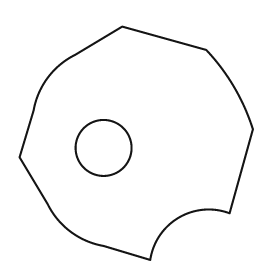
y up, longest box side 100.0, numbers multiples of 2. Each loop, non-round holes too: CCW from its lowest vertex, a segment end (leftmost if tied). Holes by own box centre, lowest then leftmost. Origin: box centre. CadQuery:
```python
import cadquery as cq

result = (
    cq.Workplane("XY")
    .moveTo(6.0, -50.0)
    .threePointArc((18.0, -32.0), (40.0, -30.0))
    .lineTo(50.0, 6.0)
    .threePointArc((42.0, 24.0), (30.0, 40.0))
    .lineTo(-6.0, 50.0)
    .lineTo(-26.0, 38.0)
    .threePointArc((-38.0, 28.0), (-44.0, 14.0))
    .lineTo(-50.0, -6.0)
    .lineTo(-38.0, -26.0)
    .threePointArc((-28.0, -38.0), (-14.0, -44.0))
    .close()
    .moveTo(-14.0, -2.0)
    .circle(12.0)
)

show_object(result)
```